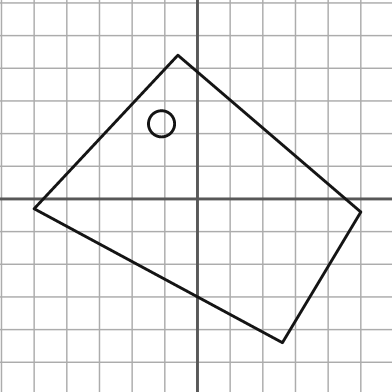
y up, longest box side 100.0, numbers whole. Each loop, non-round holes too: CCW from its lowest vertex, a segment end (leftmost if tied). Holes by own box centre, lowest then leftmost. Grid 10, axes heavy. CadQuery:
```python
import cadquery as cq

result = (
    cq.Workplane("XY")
    .moveTo(26.0, -44.0)
    .lineTo(50.0, -4.0)
    .lineTo(-6.0, 44.0)
    .lineTo(-50.0, -3.0)
    .close()
    .moveTo(-11.0, 23.0)
    .circle(4.0)
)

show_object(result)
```